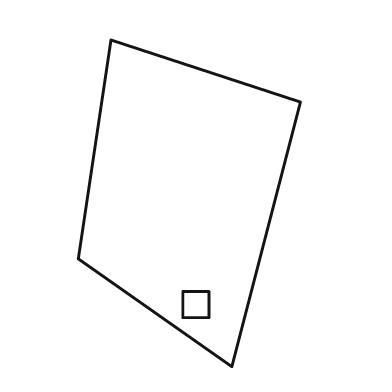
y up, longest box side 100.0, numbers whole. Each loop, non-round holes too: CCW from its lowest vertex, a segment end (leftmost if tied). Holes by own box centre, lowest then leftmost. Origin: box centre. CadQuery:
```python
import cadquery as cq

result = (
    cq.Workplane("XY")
    .moveTo(13.0, -50.0)
    .lineTo(34.0, 31.0)
    .lineTo(-24.0, 50.0)
    .lineTo(-34.0, -17.0)
    .close()
    .moveTo(-2.0, -35.0)
    .lineTo(6.0, -35.0)
    .lineTo(6.0, -27.0)
    .lineTo(-2.0, -27.0)
    .close()
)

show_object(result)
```